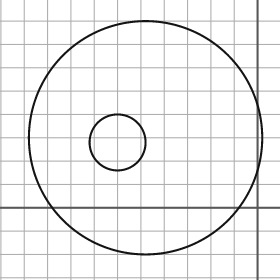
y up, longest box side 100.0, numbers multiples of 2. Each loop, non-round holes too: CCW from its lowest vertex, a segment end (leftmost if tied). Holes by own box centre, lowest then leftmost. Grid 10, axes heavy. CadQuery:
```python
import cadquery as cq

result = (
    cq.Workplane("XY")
    .moveTo(-48.0, 30.0)
    .circle(50.0)
    .moveTo(-60.0, 28.0)
    .circle(12.0)
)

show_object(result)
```